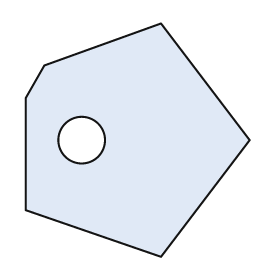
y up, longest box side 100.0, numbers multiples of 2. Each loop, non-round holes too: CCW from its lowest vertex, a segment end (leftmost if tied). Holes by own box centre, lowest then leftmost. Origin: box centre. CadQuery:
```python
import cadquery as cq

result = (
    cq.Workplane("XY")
    .moveTo(10.0, -50.0)
    .lineTo(48.0, 0.0)
    .lineTo(10.0, 50.0)
    .lineTo(-40.0, 32.0)
    .lineTo(-48.0, 18.0)
    .lineTo(-48.0, -30.0)
    .close()
    .moveTo(-24.0, 0.0)
    .circle(10.0)
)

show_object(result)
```